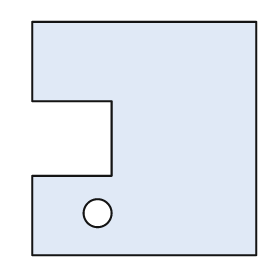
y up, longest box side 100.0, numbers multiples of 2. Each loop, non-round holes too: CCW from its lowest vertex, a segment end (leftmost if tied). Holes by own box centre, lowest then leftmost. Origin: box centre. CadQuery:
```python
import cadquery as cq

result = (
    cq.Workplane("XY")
    .moveTo(-48.0, -50.0)
    .lineTo(48.0, -50.0)
    .lineTo(48.0, 50.0)
    .lineTo(-48.0, 50.0)
    .lineTo(-48.0, 16.0)
    .lineTo(-14.0, 16.0)
    .lineTo(-14.0, -16.0)
    .lineTo(-48.0, -16.0)
    .close()
    .moveTo(-20.0, -32.0)
    .circle(6.0)
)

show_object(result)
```